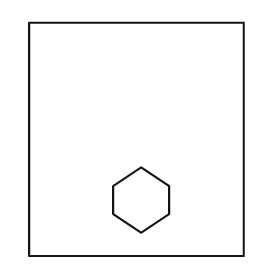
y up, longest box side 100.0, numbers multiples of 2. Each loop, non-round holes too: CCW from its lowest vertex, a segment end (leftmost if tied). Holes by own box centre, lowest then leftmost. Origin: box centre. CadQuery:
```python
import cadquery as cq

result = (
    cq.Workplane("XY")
    .moveTo(-46.0, -50.0)
    .lineTo(46.0, -50.0)
    .lineTo(46.0, 50.0)
    .lineTo(-46.0, 50.0)
    .close()
    .moveTo(2.0, -40.0)
    .lineTo(14.0, -32.0)
    .lineTo(14.0, -20.0)
    .lineTo(2.0, -12.0)
    .lineTo(-10.0, -20.0)
    .lineTo(-10.0, -32.0)
    .close()
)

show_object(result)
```